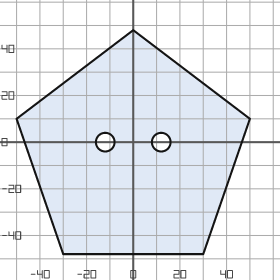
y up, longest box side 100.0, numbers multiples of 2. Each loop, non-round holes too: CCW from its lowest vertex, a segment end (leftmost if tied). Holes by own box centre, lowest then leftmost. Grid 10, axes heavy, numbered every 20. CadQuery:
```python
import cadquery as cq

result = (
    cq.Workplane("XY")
    .moveTo(-30.0, -48.0)
    .lineTo(30.0, -48.0)
    .lineTo(50.0, 10.0)
    .lineTo(0.0, 48.0)
    .lineTo(-50.0, 10.0)
    .close()
    .moveTo(-12.0, 0.0)
    .circle(4.0)
    .moveTo(12.0, 0.0)
    .circle(4.0)
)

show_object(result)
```